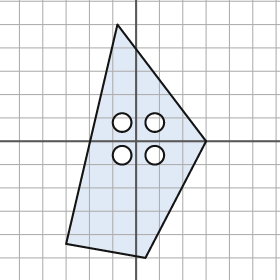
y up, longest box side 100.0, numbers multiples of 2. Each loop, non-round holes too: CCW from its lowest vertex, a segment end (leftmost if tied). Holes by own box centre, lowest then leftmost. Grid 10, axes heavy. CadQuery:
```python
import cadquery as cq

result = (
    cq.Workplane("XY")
    .moveTo(4.0, -50.0)
    .lineTo(30.0, 0.0)
    .lineTo(-8.0, 50.0)
    .lineTo(-30.0, -44.0)
    .close()
    .moveTo(-6.0, -6.0)
    .circle(4.0)
    .moveTo(8.0, -6.0)
    .circle(4.0)
    .moveTo(-6.0, 8.0)
    .circle(4.0)
    .moveTo(8.0, 8.0)
    .circle(4.0)
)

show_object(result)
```